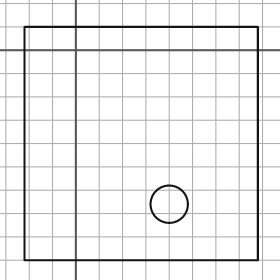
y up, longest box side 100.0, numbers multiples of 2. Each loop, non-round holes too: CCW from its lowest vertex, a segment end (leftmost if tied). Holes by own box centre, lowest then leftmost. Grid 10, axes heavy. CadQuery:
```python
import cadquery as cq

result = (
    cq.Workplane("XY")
    .moveTo(-22.0, -90.0)
    .lineTo(78.0, -90.0)
    .lineTo(78.0, 10.0)
    .lineTo(-22.0, 10.0)
    .close()
    .moveTo(40.0, -66.0)
    .circle(8.0)
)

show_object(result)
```